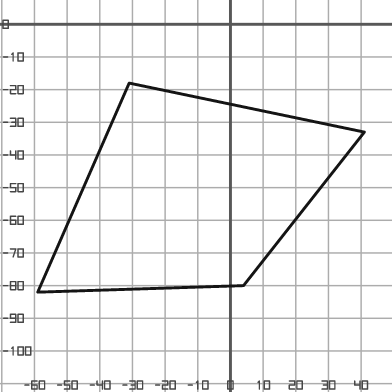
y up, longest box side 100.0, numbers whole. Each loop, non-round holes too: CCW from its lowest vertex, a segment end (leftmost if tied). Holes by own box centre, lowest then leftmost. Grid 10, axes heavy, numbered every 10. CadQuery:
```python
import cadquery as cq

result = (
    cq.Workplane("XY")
    .moveTo(-59.0, -82.0)
    .lineTo(4.0, -80.0)
    .lineTo(41.0, -33.0)
    .lineTo(-31.0, -18.0)
    .close()
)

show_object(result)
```